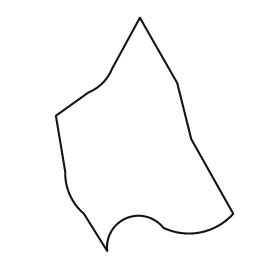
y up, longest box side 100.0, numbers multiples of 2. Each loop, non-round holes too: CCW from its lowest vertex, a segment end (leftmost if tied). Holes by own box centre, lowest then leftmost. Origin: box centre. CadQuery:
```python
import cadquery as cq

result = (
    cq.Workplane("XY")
    .moveTo(-16.0, -50.0)
    .threePointArc((-8.0, -36.0), (8.0, -40.0))
    .threePointArc((24.0, -42.0), (38.0, -34.0))
    .lineTo(20.0, -2.0)
    .lineTo(14.0, 22.0)
    .lineTo(-2.0, 50.0)
    .lineTo(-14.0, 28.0)
    .threePointArc((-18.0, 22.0), (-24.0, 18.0))
    .lineTo(-38.0, 8.0)
    .lineTo(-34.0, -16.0)
    .threePointArc((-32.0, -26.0), (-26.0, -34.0))
    .close()
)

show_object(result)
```